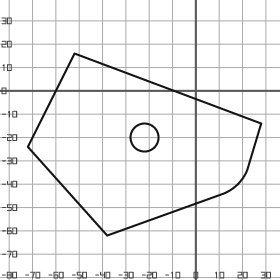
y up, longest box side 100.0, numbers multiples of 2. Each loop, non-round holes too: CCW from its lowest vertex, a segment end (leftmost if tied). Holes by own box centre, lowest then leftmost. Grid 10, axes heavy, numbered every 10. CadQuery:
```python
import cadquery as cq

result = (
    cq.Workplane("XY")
    .moveTo(-38.0, -62.0)
    .lineTo(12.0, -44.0)
    .threePointArc((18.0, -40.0), (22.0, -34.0))
    .lineTo(28.0, -14.0)
    .lineTo(-52.0, 16.0)
    .lineTo(-72.0, -24.0)
    .close()
    .moveTo(-22.0, -20.0)
    .circle(6.0)
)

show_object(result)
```